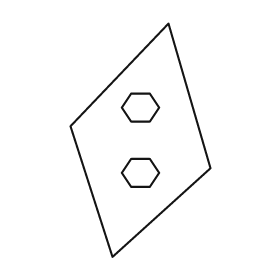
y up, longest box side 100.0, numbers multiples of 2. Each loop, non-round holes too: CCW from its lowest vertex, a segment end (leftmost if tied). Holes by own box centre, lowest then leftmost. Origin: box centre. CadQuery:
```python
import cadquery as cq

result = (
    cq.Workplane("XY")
    .moveTo(-12.0, -50.0)
    .lineTo(30.0, -12.0)
    .lineTo(12.0, 50.0)
    .lineTo(-30.0, 6.0)
    .close()
    .moveTo(-4.0, -20.0)
    .lineTo(4.0, -20.0)
    .lineTo(8.0, -14.0)
    .lineTo(4.0, -8.0)
    .lineTo(-4.0, -8.0)
    .lineTo(-8.0, -14.0)
    .close()
    .moveTo(-4.0, 8.0)
    .lineTo(4.0, 8.0)
    .lineTo(8.0, 14.0)
    .lineTo(4.0, 20.0)
    .lineTo(-4.0, 20.0)
    .lineTo(-8.0, 14.0)
    .close()
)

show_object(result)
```